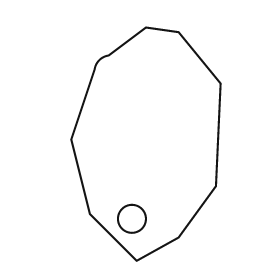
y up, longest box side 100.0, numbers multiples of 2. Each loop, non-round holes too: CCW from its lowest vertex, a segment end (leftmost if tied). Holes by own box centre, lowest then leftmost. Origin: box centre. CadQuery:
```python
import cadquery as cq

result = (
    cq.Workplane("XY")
    .moveTo(-4.0, -50.0)
    .lineTo(14.0, -40.0)
    .lineTo(30.0, -18.0)
    .lineTo(32.0, 26.0)
    .lineTo(14.0, 48.0)
    .lineTo(0.0, 50.0)
    .lineTo(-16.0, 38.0)
    .threePointArc((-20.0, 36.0), (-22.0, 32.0))
    .lineTo(-32.0, 2.0)
    .lineTo(-24.0, -30.0)
    .close()
    .moveTo(-6.0, -32.0)
    .circle(6.0)
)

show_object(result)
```